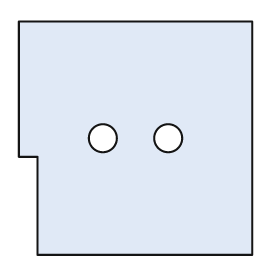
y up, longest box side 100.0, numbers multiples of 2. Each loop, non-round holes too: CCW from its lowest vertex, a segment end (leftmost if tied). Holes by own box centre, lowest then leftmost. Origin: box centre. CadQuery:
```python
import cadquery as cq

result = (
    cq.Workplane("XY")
    .moveTo(-42.0, -50.0)
    .lineTo(50.0, -50.0)
    .lineTo(50.0, 50.0)
    .lineTo(-50.0, 50.0)
    .lineTo(-50.0, -8.0)
    .lineTo(-42.0, -8.0)
    .close()
    .moveTo(-14.0, 0.0)
    .circle(6.0)
    .moveTo(14.0, 0.0)
    .circle(6.0)
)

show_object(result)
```